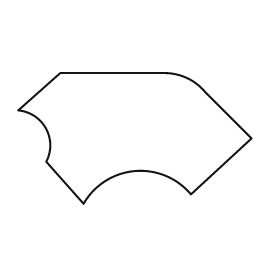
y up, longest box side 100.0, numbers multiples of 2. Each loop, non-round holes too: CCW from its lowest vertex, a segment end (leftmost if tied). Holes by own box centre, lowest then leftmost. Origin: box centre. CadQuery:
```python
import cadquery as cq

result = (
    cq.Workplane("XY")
    .moveTo(-22.0, -28.0)
    .threePointArc((0.0, -14.0), (24.0, -24.0))
    .lineTo(50.0, 0.0)
    .lineTo(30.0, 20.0)
    .threePointArc((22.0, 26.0), (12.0, 28.0))
    .lineTo(-32.0, 28.0)
    .lineTo(-50.0, 12.0)
    .threePointArc((-38.0, 4.0), (-38.0, -10.0))
    .close()
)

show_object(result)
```